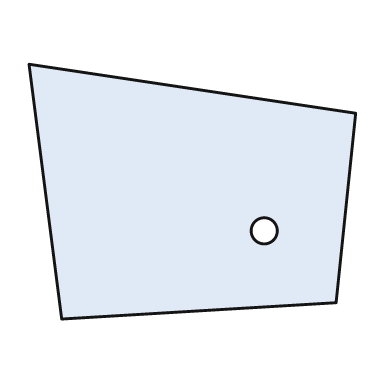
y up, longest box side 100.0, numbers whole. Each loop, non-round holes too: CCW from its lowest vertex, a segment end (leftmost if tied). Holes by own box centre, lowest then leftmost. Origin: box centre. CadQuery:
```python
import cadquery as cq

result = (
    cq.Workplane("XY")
    .moveTo(-40.0, -39.0)
    .lineTo(44.0, -34.0)
    .lineTo(50.0, 24.0)
    .lineTo(-50.0, 39.0)
    .close()
    .moveTo(22.0, -12.0)
    .circle(4.0)
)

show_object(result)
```